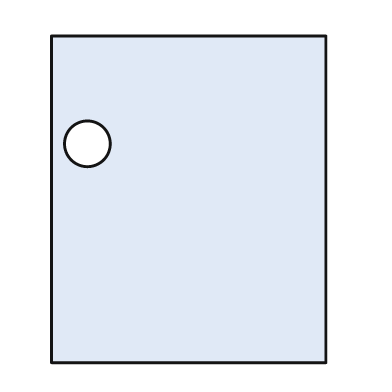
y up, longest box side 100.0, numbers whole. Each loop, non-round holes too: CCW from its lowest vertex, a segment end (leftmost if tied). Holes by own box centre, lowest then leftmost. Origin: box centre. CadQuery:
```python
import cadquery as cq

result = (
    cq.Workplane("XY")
    .moveTo(-42.0, -50.0)
    .lineTo(42.0, -50.0)
    .lineTo(42.0, 50.0)
    .lineTo(-42.0, 50.0)
    .close()
    .moveTo(-31.0, 17.0)
    .circle(7.0)
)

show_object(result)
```